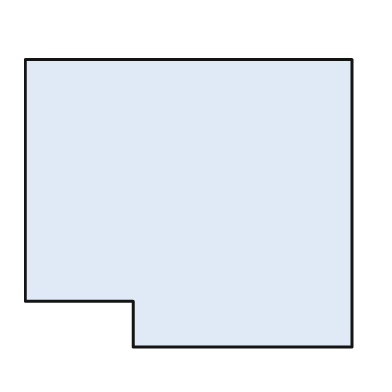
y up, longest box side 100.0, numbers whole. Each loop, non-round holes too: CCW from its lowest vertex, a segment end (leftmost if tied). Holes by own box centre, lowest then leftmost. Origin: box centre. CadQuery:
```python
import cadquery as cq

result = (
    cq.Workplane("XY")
    .moveTo(-17.0, -44.0)
    .lineTo(50.0, -44.0)
    .lineTo(50.0, 44.0)
    .lineTo(-50.0, 44.0)
    .lineTo(-50.0, -30.0)
    .lineTo(-17.0, -30.0)
    .close()
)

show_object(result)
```